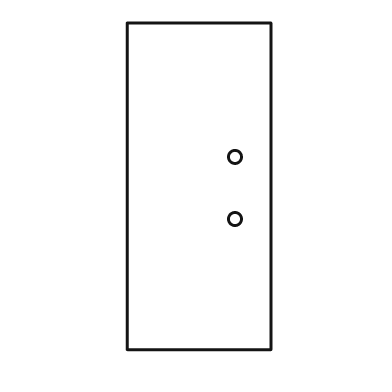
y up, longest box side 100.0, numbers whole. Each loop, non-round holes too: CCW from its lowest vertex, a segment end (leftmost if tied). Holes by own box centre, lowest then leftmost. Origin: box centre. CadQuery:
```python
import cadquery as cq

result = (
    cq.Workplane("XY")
    .moveTo(-22.0, -50.0)
    .lineTo(22.0, -50.0)
    .lineTo(22.0, 50.0)
    .lineTo(-22.0, 50.0)
    .close()
    .moveTo(11.0, -10.0)
    .circle(2.0)
    .moveTo(11.0, 9.0)
    .circle(2.0)
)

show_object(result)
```